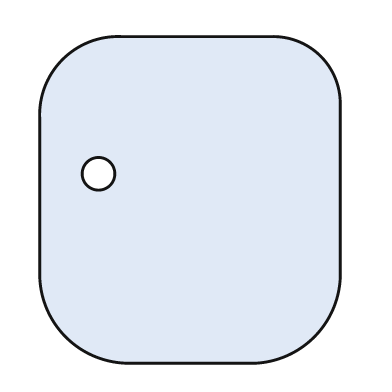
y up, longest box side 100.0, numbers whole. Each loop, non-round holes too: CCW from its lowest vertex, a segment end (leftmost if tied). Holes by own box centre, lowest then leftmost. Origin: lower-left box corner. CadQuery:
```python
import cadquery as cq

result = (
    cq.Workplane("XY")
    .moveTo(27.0, 0.0)
    .lineTo(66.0, 0.0)
    .threePointArc((84.0, 8.0), (92.0, 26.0))
    .lineTo(92.0, 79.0)
    .threePointArc((86.0, 94.0), (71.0, 100.0))
    .lineTo(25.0, 100.0)
    .threePointArc((7.0, 93.0), (0.0, 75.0))
    .lineTo(0.0, 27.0)
    .threePointArc((8.0, 8.0), (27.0, 0.0))
    .close()
    .moveTo(18.0, 58.0)
    .circle(5.0)
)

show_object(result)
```